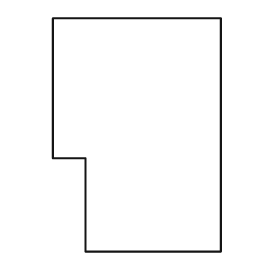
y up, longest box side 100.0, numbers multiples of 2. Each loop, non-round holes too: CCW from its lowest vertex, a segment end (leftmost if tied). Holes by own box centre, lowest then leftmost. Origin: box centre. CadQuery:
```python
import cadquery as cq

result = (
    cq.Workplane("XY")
    .moveTo(-22.0, -50.0)
    .lineTo(36.0, -50.0)
    .lineTo(36.0, 50.0)
    .lineTo(-36.0, 50.0)
    .lineTo(-36.0, -10.0)
    .lineTo(-22.0, -10.0)
    .close()
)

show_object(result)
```